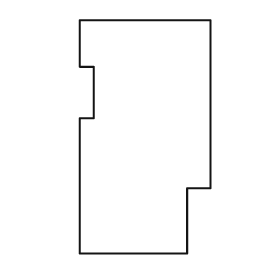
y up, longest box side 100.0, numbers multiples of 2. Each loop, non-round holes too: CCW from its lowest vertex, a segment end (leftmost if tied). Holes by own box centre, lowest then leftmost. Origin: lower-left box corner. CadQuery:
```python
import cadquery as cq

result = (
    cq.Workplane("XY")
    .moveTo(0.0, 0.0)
    .lineTo(46.0, 0.0)
    .lineTo(46.0, 28.0)
    .lineTo(56.0, 28.0)
    .lineTo(56.0, 100.0)
    .lineTo(0.0, 100.0)
    .lineTo(0.0, 80.0)
    .lineTo(6.0, 80.0)
    .lineTo(6.0, 58.0)
    .lineTo(0.0, 58.0)
    .close()
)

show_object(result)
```